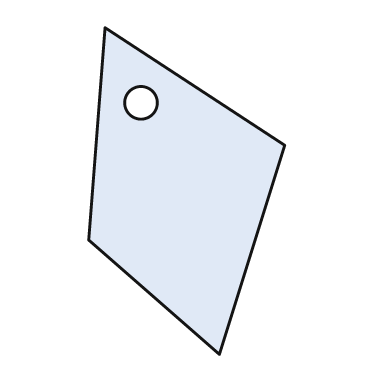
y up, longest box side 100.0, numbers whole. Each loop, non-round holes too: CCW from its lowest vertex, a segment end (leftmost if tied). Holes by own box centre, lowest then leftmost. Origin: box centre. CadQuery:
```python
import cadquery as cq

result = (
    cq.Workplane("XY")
    .moveTo(10.0, -50.0)
    .lineTo(30.0, 14.0)
    .lineTo(-25.0, 50.0)
    .lineTo(-30.0, -15.0)
    .close()
    .moveTo(-14.0, 27.0)
    .circle(5.0)
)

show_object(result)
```